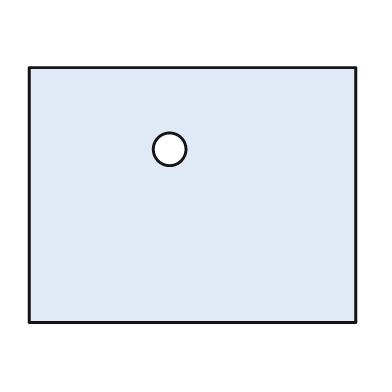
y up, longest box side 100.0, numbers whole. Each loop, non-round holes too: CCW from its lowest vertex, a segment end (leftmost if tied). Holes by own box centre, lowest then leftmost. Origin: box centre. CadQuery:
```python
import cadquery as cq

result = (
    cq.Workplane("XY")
    .moveTo(-50.0, -39.0)
    .lineTo(50.0, -39.0)
    .lineTo(50.0, 39.0)
    .lineTo(-50.0, 39.0)
    .close()
    .moveTo(-7.0, 14.0)
    .circle(5.0)
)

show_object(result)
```